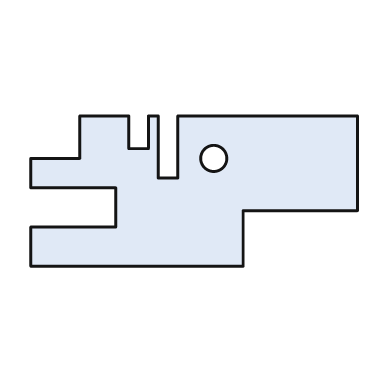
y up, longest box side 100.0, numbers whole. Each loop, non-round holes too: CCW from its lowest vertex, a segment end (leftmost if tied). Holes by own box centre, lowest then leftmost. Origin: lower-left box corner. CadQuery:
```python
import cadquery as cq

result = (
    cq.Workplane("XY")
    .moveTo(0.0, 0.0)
    .lineTo(65.0, 0.0)
    .lineTo(65.0, 17.0)
    .lineTo(100.0, 17.0)
    .lineTo(100.0, 46.0)
    .lineTo(45.0, 46.0)
    .lineTo(45.0, 27.0)
    .lineTo(39.0, 27.0)
    .lineTo(39.0, 46.0)
    .lineTo(36.0, 46.0)
    .lineTo(36.0, 36.0)
    .lineTo(30.0, 36.0)
    .lineTo(30.0, 46.0)
    .lineTo(15.0, 46.0)
    .lineTo(15.0, 33.0)
    .lineTo(0.0, 33.0)
    .lineTo(0.0, 24.0)
    .lineTo(26.0, 24.0)
    .lineTo(26.0, 12.0)
    .lineTo(0.0, 12.0)
    .close()
    .moveTo(56.0, 33.0)
    .circle(4.0)
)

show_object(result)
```